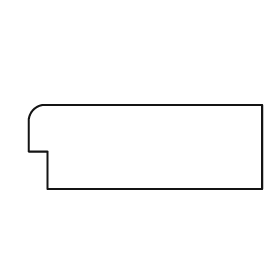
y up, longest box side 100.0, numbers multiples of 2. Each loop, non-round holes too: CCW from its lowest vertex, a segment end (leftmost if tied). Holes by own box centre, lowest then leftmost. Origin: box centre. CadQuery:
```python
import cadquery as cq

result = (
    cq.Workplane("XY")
    .moveTo(-42.0, -18.0)
    .lineTo(50.0, -18.0)
    .lineTo(50.0, 18.0)
    .lineTo(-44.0, 18.0)
    .threePointArc((-48.0, 16.0), (-50.0, 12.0))
    .lineTo(-50.0, -2.0)
    .lineTo(-42.0, -2.0)
    .close()
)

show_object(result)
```